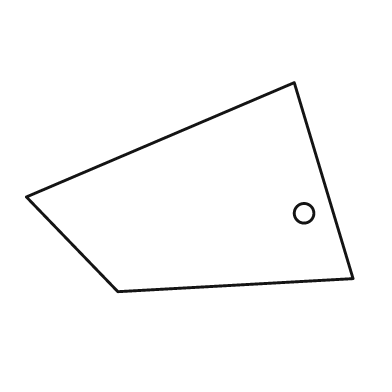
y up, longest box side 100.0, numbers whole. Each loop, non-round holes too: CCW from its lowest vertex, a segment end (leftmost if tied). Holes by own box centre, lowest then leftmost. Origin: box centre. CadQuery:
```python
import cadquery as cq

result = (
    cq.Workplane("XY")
    .moveTo(-22.0, -32.0)
    .lineTo(50.0, -28.0)
    .lineTo(32.0, 32.0)
    .lineTo(-50.0, -3.0)
    .close()
    .moveTo(35.0, -8.0)
    .circle(3.0)
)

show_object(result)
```